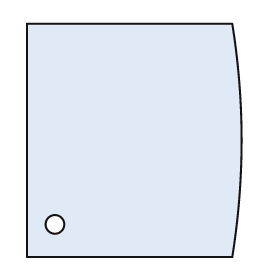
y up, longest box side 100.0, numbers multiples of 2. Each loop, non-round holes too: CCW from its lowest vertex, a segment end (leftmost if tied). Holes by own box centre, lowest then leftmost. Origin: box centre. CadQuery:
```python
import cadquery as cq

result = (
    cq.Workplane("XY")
    .moveTo(-46.0, -50.0)
    .lineTo(42.0, -50.0)
    .threePointArc((46.0, 0.0), (42.0, 50.0))
    .lineTo(-46.0, 50.0)
    .close()
    .moveTo(-34.0, -36.0)
    .circle(4.0)
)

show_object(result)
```